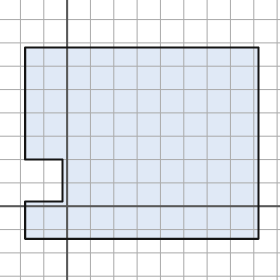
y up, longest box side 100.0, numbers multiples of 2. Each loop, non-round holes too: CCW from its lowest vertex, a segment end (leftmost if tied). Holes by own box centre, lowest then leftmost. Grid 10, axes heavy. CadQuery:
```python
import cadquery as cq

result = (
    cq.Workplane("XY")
    .moveTo(-18.0, -14.0)
    .lineTo(82.0, -14.0)
    .lineTo(82.0, 68.0)
    .lineTo(-18.0, 68.0)
    .lineTo(-18.0, 20.0)
    .lineTo(-2.0, 20.0)
    .lineTo(-2.0, 2.0)
    .lineTo(-18.0, 2.0)
    .close()
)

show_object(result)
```